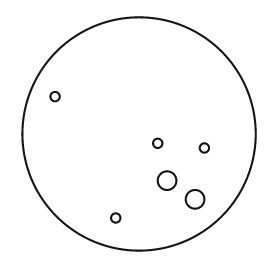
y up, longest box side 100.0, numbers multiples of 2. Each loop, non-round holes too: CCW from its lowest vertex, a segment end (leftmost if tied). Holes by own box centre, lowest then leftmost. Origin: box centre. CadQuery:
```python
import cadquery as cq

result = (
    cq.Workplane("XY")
    .moveTo(0.0, 0.0)
    .circle(50.0)
    .moveTo(-10.0, -36.0)
    .circle(2.0)
    .moveTo(24.0, -28.0)
    .circle(4.0)
    .moveTo(12.0, -20.0)
    .circle(4.0)
    .moveTo(28.0, -6.0)
    .circle(2.0)
    .moveTo(8.0, -4.0)
    .circle(2.0)
    .moveTo(-36.0, 16.0)
    .circle(2.0)
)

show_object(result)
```